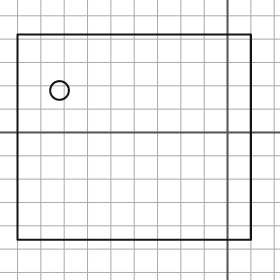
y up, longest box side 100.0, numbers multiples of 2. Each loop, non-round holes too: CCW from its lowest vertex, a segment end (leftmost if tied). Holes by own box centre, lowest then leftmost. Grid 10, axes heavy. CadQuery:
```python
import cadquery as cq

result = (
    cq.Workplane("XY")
    .moveTo(-90.0, -46.0)
    .lineTo(10.0, -46.0)
    .lineTo(10.0, 42.0)
    .lineTo(-90.0, 42.0)
    .close()
    .moveTo(-72.0, 18.0)
    .circle(4.0)
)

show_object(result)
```